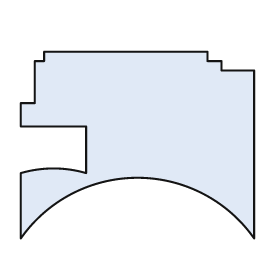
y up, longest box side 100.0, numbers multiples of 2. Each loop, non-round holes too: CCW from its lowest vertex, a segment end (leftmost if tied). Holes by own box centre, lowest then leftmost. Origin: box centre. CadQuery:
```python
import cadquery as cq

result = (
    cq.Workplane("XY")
    .moveTo(-50.0, -40.0)
    .threePointArc((0.0, -14.0), (50.0, -40.0))
    .lineTo(50.0, 32.0)
    .lineTo(36.0, 32.0)
    .lineTo(36.0, 36.0)
    .lineTo(30.0, 36.0)
    .lineTo(30.0, 40.0)
    .lineTo(-40.0, 40.0)
    .lineTo(-40.0, 36.0)
    .lineTo(-44.0, 36.0)
    .lineTo(-44.0, 18.0)
    .lineTo(-50.0, 18.0)
    .lineTo(-50.0, 8.0)
    .lineTo(-22.0, 8.0)
    .lineTo(-22.0, -12.0)
    .threePointArc((-36.0, -10.0), (-50.0, -12.0))
    .close()
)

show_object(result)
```